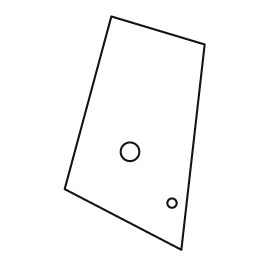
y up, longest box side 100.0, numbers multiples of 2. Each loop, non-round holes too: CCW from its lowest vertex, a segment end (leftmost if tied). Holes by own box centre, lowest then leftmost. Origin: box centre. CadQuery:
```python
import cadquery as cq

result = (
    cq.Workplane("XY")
    .moveTo(20.0, -50.0)
    .lineTo(30.0, 38.0)
    .lineTo(-10.0, 50.0)
    .lineTo(-30.0, -24.0)
    .close()
    .moveTo(16.0, -30.0)
    .circle(2.0)
    .moveTo(-2.0, -8.0)
    .circle(4.0)
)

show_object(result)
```